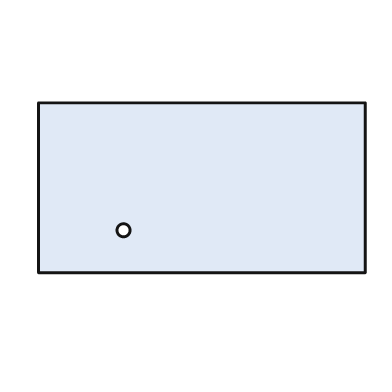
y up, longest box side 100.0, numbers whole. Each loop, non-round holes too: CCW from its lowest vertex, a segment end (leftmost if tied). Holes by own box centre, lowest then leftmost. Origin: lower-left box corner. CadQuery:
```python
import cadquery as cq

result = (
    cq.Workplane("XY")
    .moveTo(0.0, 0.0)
    .lineTo(100.0, 0.0)
    .lineTo(100.0, 52.0)
    .lineTo(0.0, 52.0)
    .close()
    .moveTo(26.0, 13.0)
    .circle(2.0)
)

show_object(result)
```